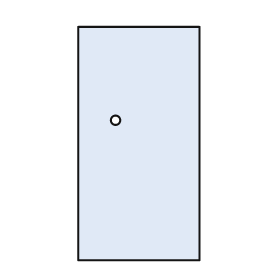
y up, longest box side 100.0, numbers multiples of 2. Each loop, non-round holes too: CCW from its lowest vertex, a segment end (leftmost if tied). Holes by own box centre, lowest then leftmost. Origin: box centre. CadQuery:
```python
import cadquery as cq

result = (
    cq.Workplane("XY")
    .moveTo(-26.0, -50.0)
    .lineTo(26.0, -50.0)
    .lineTo(26.0, 50.0)
    .lineTo(-26.0, 50.0)
    .close()
    .moveTo(-10.0, 10.0)
    .circle(2.0)
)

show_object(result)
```